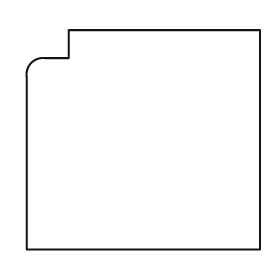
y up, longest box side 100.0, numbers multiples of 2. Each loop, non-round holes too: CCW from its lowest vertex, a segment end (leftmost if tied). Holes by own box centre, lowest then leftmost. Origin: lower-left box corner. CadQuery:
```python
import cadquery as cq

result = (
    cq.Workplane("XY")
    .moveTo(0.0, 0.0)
    .lineTo(100.0, 0.0)
    .lineTo(100.0, 94.0)
    .lineTo(18.0, 94.0)
    .lineTo(18.0, 82.0)
    .lineTo(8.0, 82.0)
    .threePointArc((2.0, 80.0), (0.0, 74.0))
    .close()
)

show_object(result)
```